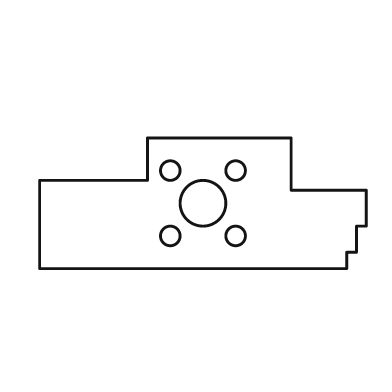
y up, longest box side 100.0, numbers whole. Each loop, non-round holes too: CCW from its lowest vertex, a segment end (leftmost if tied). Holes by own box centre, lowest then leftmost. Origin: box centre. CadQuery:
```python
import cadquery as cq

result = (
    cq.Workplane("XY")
    .moveTo(-50.0, -20.0)
    .lineTo(44.0, -20.0)
    .lineTo(44.0, -15.0)
    .lineTo(47.0, -15.0)
    .lineTo(47.0, -7.0)
    .lineTo(50.0, -7.0)
    .lineTo(50.0, 4.0)
    .lineTo(27.0, 4.0)
    .lineTo(27.0, 20.0)
    .lineTo(-17.0, 20.0)
    .lineTo(-17.0, 7.0)
    .lineTo(-50.0, 7.0)
    .close()
    .moveTo(-10.0, -10.0)
    .circle(3.0)
    .moveTo(10.0, -10.0)
    .circle(3.0)
    .moveTo(0.0, 0.0)
    .circle(7.0)
    .moveTo(-10.0, 10.0)
    .circle(3.0)
    .moveTo(10.0, 10.0)
    .circle(3.0)
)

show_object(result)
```